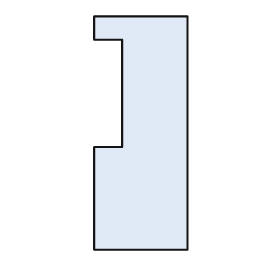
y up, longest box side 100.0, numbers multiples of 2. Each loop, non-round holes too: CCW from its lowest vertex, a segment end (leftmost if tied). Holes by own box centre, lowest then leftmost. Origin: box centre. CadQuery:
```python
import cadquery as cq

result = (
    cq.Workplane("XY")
    .moveTo(-20.0, -50.0)
    .lineTo(20.0, -50.0)
    .lineTo(20.0, 50.0)
    .lineTo(-20.0, 50.0)
    .lineTo(-20.0, 40.0)
    .lineTo(-8.0, 40.0)
    .lineTo(-8.0, -6.0)
    .lineTo(-20.0, -6.0)
    .close()
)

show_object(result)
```